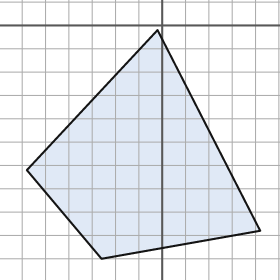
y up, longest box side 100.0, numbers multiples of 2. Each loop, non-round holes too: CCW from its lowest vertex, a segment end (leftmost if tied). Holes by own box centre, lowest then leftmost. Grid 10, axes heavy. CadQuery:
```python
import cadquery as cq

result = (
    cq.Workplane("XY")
    .moveTo(-26.0, -100.0)
    .lineTo(42.0, -88.0)
    .lineTo(-2.0, -2.0)
    .lineTo(-58.0, -62.0)
    .close()
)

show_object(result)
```